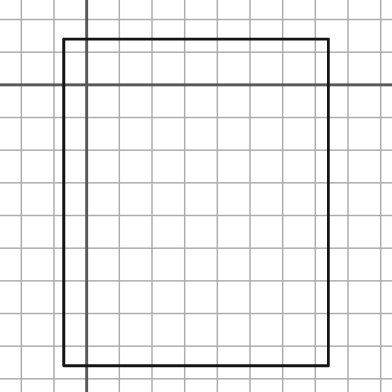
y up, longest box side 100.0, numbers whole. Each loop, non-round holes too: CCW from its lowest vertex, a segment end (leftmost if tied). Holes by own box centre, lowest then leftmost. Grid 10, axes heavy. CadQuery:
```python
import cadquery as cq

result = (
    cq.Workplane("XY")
    .moveTo(-7.0, -86.0)
    .lineTo(74.0, -86.0)
    .lineTo(74.0, 14.0)
    .lineTo(-7.0, 14.0)
    .close()
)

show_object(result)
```